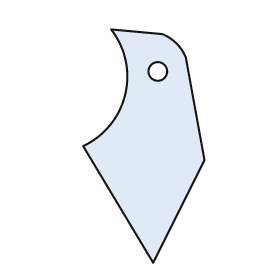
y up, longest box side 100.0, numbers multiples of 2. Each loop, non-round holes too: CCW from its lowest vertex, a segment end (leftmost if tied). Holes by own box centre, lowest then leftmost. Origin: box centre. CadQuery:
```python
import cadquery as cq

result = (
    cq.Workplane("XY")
    .moveTo(4.0, -50.0)
    .lineTo(26.0, -6.0)
    .lineTo(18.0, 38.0)
    .threePointArc((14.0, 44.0), (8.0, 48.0))
    .lineTo(-14.0, 50.0)
    .threePointArc((-8.0, 22.0), (-26.0, 0.0))
    .close()
    .moveTo(6.0, 32.0)
    .circle(4.0)
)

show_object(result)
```